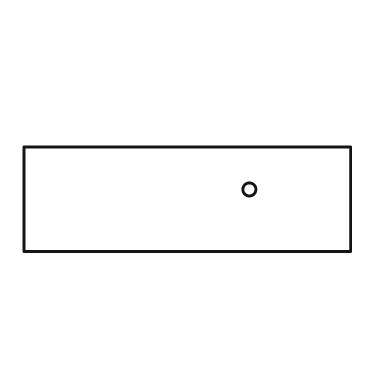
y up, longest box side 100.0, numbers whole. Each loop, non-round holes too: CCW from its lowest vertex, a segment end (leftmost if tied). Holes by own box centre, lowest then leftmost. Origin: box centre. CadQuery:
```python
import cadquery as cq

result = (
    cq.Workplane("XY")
    .moveTo(-50.0, -16.0)
    .lineTo(50.0, -16.0)
    .lineTo(50.0, 16.0)
    .lineTo(-50.0, 16.0)
    .close()
    .moveTo(19.0, 3.0)
    .circle(2.0)
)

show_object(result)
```